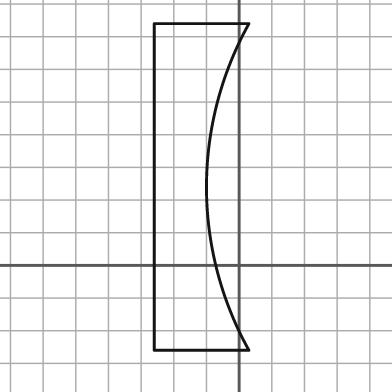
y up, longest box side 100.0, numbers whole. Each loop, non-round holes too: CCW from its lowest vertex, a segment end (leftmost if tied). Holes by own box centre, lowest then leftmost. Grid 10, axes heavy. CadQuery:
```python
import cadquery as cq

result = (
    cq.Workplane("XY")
    .moveTo(-26.0, -26.0)
    .lineTo(3.0, -26.0)
    .threePointArc((-10.0, 24.0), (3.0, 74.0))
    .lineTo(-26.0, 74.0)
    .close()
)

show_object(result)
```